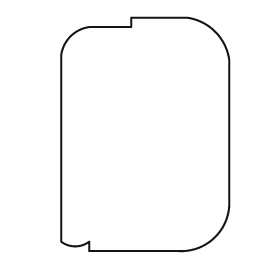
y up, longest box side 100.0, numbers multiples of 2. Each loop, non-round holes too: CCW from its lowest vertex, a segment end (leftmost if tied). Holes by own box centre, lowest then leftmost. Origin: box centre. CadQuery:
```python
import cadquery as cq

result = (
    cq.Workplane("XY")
    .moveTo(-24.0, -50.0)
    .lineTo(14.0, -50.0)
    .threePointArc((30.0, -44.0), (36.0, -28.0))
    .lineTo(36.0, 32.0)
    .threePointArc((30.0, 44.0), (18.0, 50.0))
    .lineTo(-6.0, 50.0)
    .lineTo(-6.0, 46.0)
    .lineTo(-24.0, 46.0)
    .threePointArc((-32.0, 42.0), (-36.0, 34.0))
    .lineTo(-36.0, -46.0)
    .threePointArc((-30.0, -48.0), (-24.0, -46.0))
    .close()
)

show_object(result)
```